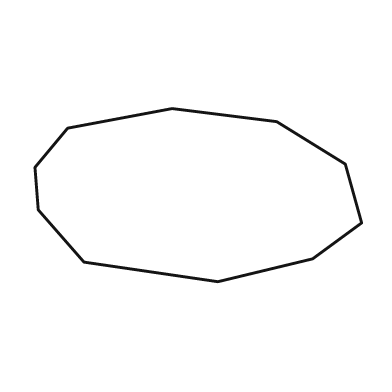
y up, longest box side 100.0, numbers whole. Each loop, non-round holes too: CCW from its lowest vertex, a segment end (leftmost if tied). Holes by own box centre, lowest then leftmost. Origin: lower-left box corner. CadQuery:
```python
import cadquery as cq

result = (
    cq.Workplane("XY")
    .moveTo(56.0, 0.0)
    .lineTo(85.0, 7.0)
    .lineTo(100.0, 18.0)
    .lineTo(95.0, 36.0)
    .lineTo(74.0, 49.0)
    .lineTo(42.0, 53.0)
    .lineTo(10.0, 47.0)
    .lineTo(0.0, 35.0)
    .lineTo(1.0, 22.0)
    .lineTo(15.0, 6.0)
    .close()
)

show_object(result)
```